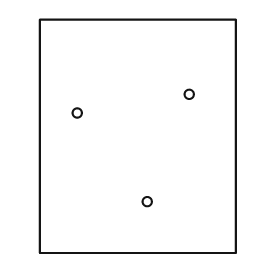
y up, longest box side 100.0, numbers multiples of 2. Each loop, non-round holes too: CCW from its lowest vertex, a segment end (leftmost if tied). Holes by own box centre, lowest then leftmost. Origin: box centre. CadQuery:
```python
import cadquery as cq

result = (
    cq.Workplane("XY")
    .moveTo(-42.0, -50.0)
    .lineTo(42.0, -50.0)
    .lineTo(42.0, 50.0)
    .lineTo(-42.0, 50.0)
    .close()
    .moveTo(4.0, -28.0)
    .circle(2.0)
    .moveTo(-26.0, 10.0)
    .circle(2.0)
    .moveTo(22.0, 18.0)
    .circle(2.0)
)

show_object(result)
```